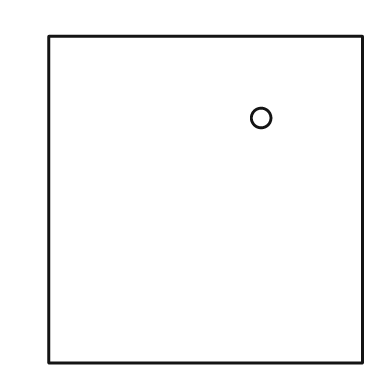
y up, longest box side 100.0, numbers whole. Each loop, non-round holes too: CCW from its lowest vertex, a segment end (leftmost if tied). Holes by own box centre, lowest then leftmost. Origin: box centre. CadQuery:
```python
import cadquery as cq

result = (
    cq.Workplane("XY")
    .moveTo(-48.0, -50.0)
    .lineTo(48.0, -50.0)
    .lineTo(48.0, 50.0)
    .lineTo(-48.0, 50.0)
    .close()
    .moveTo(17.0, 25.0)
    .circle(3.0)
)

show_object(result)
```